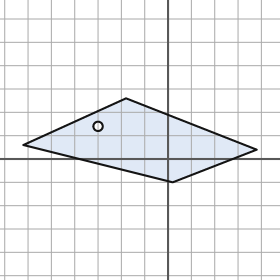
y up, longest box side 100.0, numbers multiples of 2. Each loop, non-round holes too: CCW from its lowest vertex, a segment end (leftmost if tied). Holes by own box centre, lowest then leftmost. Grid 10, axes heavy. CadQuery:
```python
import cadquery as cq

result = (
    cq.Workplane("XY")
    .moveTo(2.0, -10.0)
    .lineTo(38.0, 4.0)
    .lineTo(-18.0, 26.0)
    .lineTo(-62.0, 6.0)
    .close()
    .moveTo(-30.0, 14.0)
    .circle(2.0)
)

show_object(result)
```